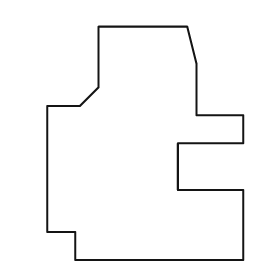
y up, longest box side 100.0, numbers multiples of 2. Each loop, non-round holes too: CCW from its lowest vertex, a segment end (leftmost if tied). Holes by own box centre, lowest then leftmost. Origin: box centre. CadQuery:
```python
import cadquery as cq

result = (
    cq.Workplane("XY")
    .moveTo(-30.0, -50.0)
    .lineTo(42.0, -50.0)
    .lineTo(42.0, -20.0)
    .lineTo(14.0, -20.0)
    .lineTo(14.0, 0.0)
    .lineTo(42.0, 0.0)
    .lineTo(42.0, 12.0)
    .lineTo(22.0, 12.0)
    .lineTo(22.0, 34.0)
    .lineTo(18.0, 50.0)
    .lineTo(-20.0, 50.0)
    .lineTo(-20.0, 24.0)
    .lineTo(-28.0, 16.0)
    .lineTo(-42.0, 16.0)
    .lineTo(-42.0, -38.0)
    .lineTo(-30.0, -38.0)
    .close()
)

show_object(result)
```